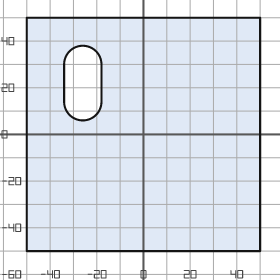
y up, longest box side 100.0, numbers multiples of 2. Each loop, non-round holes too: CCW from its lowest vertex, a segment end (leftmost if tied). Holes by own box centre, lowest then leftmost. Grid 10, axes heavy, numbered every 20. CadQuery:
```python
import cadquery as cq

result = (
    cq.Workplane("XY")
    .moveTo(-50.0, -50.0)
    .lineTo(50.0, -50.0)
    .lineTo(50.0, 50.0)
    .lineTo(-50.0, 50.0)
    .close()
    .moveTo(-34.0, 14.0)
    .threePointArc((-26.0, 6.0), (-18.0, 14.0))
    .lineTo(-18.0, 30.0)
    .threePointArc((-26.0, 38.0), (-34.0, 30.0))
    .close()
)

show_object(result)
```